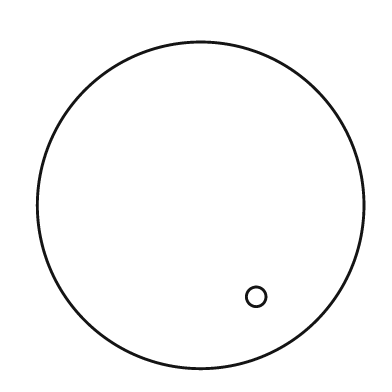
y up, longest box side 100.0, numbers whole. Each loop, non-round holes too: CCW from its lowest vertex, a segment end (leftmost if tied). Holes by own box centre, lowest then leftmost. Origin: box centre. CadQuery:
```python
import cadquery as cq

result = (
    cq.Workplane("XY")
    .moveTo(0.0, 0.0)
    .circle(50.0)
    .moveTo(17.0, -28.0)
    .circle(3.0)
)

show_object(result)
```